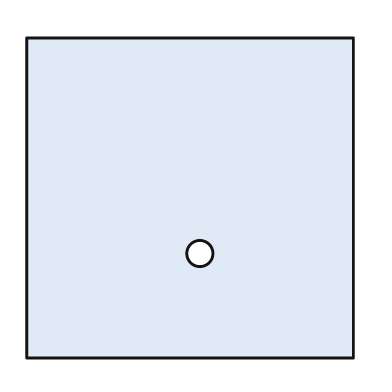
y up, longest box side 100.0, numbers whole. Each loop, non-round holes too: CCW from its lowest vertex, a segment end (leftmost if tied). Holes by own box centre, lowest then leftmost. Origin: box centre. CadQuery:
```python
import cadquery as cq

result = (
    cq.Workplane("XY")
    .moveTo(-50.0, -49.0)
    .lineTo(50.0, -49.0)
    .lineTo(50.0, 49.0)
    .lineTo(-50.0, 49.0)
    .close()
    .moveTo(3.0, -17.0)
    .circle(4.0)
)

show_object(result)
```